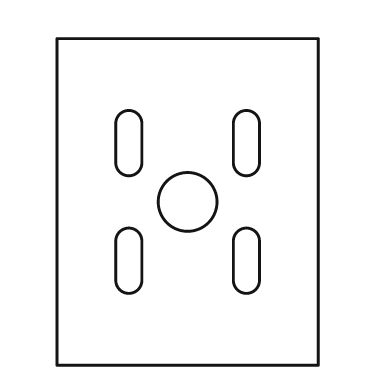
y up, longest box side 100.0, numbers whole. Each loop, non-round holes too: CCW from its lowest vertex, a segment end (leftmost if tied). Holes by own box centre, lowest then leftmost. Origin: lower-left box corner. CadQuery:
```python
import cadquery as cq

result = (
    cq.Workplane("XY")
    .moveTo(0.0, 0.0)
    .lineTo(80.0, 0.0)
    .lineTo(80.0, 100.0)
    .lineTo(0.0, 100.0)
    .close()
    .moveTo(18.0, 26.0)
    .threePointArc((22.0, 22.0), (26.0, 26.0))
    .lineTo(26.0, 38.0)
    .threePointArc((22.0, 42.0), (18.0, 38.0))
    .close()
    .moveTo(54.0, 26.0)
    .threePointArc((58.0, 22.0), (62.0, 26.0))
    .lineTo(62.0, 38.0)
    .threePointArc((58.0, 42.0), (54.0, 38.0))
    .close()
    .moveTo(40.0, 50.0)
    .circle(9.0)
    .moveTo(18.0, 62.0)
    .threePointArc((22.0, 58.0), (26.0, 62.0))
    .lineTo(26.0, 74.0)
    .threePointArc((22.0, 78.0), (18.0, 74.0))
    .close()
    .moveTo(54.0, 62.0)
    .threePointArc((58.0, 58.0), (62.0, 62.0))
    .lineTo(62.0, 74.0)
    .threePointArc((58.0, 78.0), (54.0, 74.0))
    .close()
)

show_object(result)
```